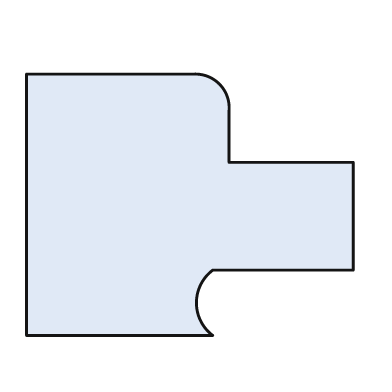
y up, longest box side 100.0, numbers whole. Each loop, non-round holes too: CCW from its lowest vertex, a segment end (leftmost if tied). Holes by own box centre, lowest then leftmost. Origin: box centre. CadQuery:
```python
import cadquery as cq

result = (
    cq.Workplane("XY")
    .moveTo(-50.0, -40.0)
    .lineTo(7.0, -40.0)
    .threePointArc((2.0, -30.0), (7.0, -20.0))
    .lineTo(50.0, -20.0)
    .lineTo(50.0, 13.0)
    .lineTo(12.0, 13.0)
    .lineTo(12.0, 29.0)
    .threePointArc((9.0, 37.0), (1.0, 40.0))
    .lineTo(-50.0, 40.0)
    .close()
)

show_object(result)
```